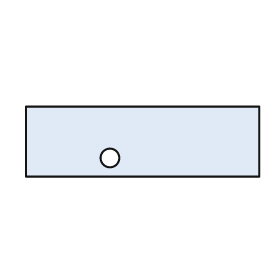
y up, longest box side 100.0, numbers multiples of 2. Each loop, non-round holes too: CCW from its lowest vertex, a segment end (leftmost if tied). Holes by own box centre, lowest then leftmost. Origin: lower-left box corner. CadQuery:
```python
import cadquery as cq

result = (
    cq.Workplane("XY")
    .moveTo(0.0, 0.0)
    .lineTo(100.0, 0.0)
    .lineTo(100.0, 30.0)
    .lineTo(0.0, 30.0)
    .close()
    .moveTo(36.0, 8.0)
    .circle(4.0)
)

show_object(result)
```